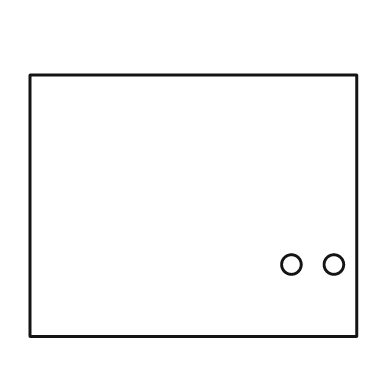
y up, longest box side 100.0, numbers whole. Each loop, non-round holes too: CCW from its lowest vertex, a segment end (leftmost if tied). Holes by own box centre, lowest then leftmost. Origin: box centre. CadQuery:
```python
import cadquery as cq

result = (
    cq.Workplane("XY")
    .moveTo(-50.0, -40.0)
    .lineTo(50.0, -40.0)
    .lineTo(50.0, 40.0)
    .lineTo(-50.0, 40.0)
    .close()
    .moveTo(30.0, -18.0)
    .circle(3.0)
    .moveTo(43.0, -18.0)
    .circle(3.0)
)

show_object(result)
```